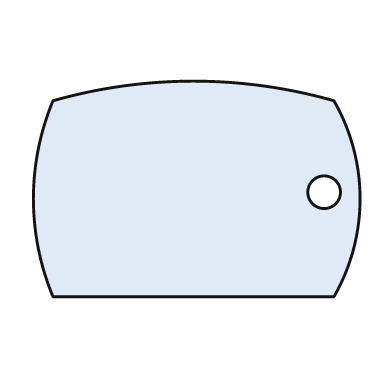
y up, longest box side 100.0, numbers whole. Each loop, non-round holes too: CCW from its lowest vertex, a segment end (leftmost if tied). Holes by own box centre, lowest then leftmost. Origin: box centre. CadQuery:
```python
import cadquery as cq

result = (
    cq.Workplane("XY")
    .moveTo(-44.0, -33.0)
    .lineTo(42.0, -33.0)
    .threePointArc((50.0, -3.0), (42.0, 27.0))
    .threePointArc((-1.0, 33.0), (-44.0, 27.0))
    .threePointArc((-50.0, -3.0), (-44.0, -33.0))
    .close()
    .moveTo(39.0, -1.0)
    .circle(5.0)
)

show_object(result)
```